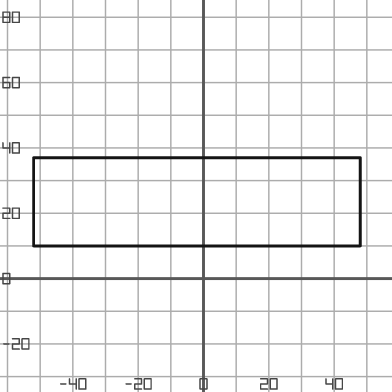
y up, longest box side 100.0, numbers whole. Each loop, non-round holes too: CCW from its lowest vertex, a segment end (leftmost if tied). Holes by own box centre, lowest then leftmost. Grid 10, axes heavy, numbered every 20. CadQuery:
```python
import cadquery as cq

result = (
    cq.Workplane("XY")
    .moveTo(-52.0, 10.0)
    .lineTo(48.0, 10.0)
    .lineTo(48.0, 37.0)
    .lineTo(-52.0, 37.0)
    .close()
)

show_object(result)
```